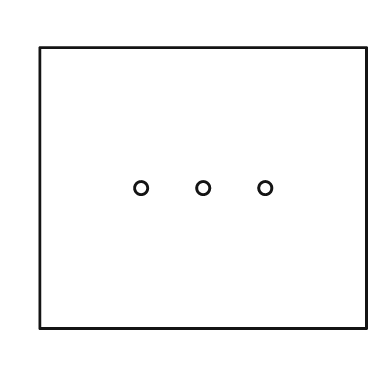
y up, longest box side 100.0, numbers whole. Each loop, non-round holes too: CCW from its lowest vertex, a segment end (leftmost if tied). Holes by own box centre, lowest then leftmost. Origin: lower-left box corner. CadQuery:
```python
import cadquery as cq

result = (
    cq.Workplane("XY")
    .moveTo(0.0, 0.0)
    .lineTo(100.0, 0.0)
    .lineTo(100.0, 86.0)
    .lineTo(0.0, 86.0)
    .close()
    .moveTo(31.0, 43.0)
    .circle(2.0)
    .moveTo(50.0, 43.0)
    .circle(2.0)
    .moveTo(69.0, 43.0)
    .circle(2.0)
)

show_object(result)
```